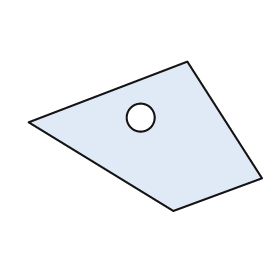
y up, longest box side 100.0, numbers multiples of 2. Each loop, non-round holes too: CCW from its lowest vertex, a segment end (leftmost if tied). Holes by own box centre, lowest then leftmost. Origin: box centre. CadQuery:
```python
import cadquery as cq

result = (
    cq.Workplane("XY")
    .moveTo(12.0, -32.0)
    .lineTo(50.0, -18.0)
    .lineTo(18.0, 32.0)
    .lineTo(-50.0, 6.0)
    .close()
    .moveTo(-2.0, 8.0)
    .circle(6.0)
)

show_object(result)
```